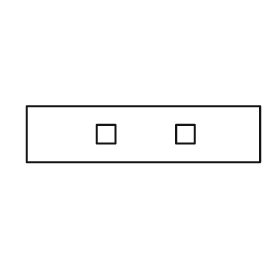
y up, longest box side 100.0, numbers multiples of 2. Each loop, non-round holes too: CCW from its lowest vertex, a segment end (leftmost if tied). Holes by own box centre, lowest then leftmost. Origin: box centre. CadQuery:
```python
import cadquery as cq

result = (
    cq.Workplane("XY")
    .moveTo(-50.0, -12.0)
    .lineTo(50.0, -12.0)
    .lineTo(50.0, 12.0)
    .lineTo(-50.0, 12.0)
    .close()
    .moveTo(-20.0, -4.0)
    .lineTo(-12.0, -4.0)
    .lineTo(-12.0, 4.0)
    .lineTo(-20.0, 4.0)
    .close()
    .moveTo(14.0, -4.0)
    .lineTo(22.0, -4.0)
    .lineTo(22.0, 4.0)
    .lineTo(14.0, 4.0)
    .close()
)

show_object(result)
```